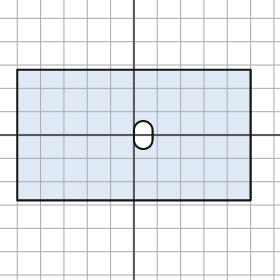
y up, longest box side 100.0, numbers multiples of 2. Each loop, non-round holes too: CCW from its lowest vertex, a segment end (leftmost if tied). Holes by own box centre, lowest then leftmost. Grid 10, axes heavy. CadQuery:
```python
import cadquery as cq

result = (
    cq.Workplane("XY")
    .moveTo(-50.0, -28.0)
    .lineTo(50.0, -28.0)
    .lineTo(50.0, 28.0)
    .lineTo(-50.0, 28.0)
    .close()
    .moveTo(0.0, -2.0)
    .threePointArc((4.0, -6.0), (8.0, -2.0))
    .lineTo(8.0, 2.0)
    .threePointArc((4.0, 6.0), (0.0, 2.0))
    .close()
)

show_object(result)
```